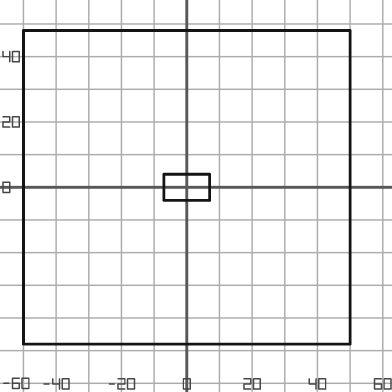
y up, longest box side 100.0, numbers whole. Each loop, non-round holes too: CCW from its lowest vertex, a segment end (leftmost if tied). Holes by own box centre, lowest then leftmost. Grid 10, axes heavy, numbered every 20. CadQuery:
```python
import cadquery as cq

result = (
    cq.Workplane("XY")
    .moveTo(-50.0, -48.0)
    .lineTo(50.0, -48.0)
    .lineTo(50.0, 48.0)
    .lineTo(-50.0, 48.0)
    .close()
    .moveTo(-7.0, -4.0)
    .lineTo(7.0, -4.0)
    .lineTo(7.0, 4.0)
    .lineTo(-7.0, 4.0)
    .close()
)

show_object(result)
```